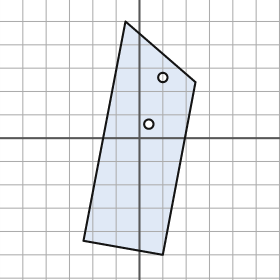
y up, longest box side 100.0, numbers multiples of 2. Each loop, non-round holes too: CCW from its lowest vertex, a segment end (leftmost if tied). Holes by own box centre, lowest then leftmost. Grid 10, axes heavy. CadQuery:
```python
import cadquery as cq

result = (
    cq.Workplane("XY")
    .moveTo(10.0, -50.0)
    .lineTo(24.0, 24.0)
    .lineTo(-6.0, 50.0)
    .lineTo(-24.0, -44.0)
    .close()
    .moveTo(4.0, 6.0)
    .circle(2.0)
    .moveTo(10.0, 26.0)
    .circle(2.0)
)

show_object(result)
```